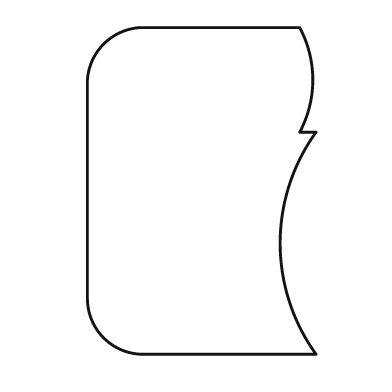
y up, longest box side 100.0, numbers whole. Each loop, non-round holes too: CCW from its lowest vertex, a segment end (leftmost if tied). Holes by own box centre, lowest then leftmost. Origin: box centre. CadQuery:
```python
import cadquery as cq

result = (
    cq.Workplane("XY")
    .moveTo(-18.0, -50.0)
    .lineTo(35.0, -50.0)
    .threePointArc((24.0, -16.0), (35.0, 18.0))
    .lineTo(30.0, 18.0)
    .threePointArc((34.0, 34.0), (30.0, 50.0))
    .lineTo(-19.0, 50.0)
    .threePointArc((-30.0, 45.0), (-35.0, 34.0))
    .lineTo(-35.0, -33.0)
    .threePointArc((-30.0, -45.0), (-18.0, -50.0))
    .close()
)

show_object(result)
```